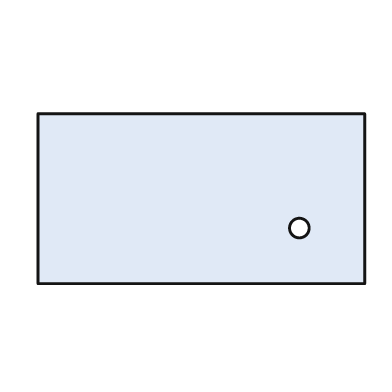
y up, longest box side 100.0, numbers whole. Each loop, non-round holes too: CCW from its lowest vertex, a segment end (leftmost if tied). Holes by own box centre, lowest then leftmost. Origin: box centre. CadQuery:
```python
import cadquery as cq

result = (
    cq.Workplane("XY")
    .moveTo(-50.0, -26.0)
    .lineTo(50.0, -26.0)
    .lineTo(50.0, 26.0)
    .lineTo(-50.0, 26.0)
    .close()
    .moveTo(30.0, -9.0)
    .circle(3.0)
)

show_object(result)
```